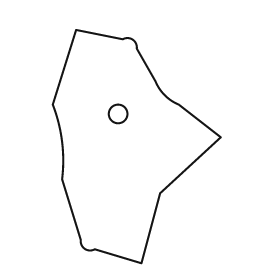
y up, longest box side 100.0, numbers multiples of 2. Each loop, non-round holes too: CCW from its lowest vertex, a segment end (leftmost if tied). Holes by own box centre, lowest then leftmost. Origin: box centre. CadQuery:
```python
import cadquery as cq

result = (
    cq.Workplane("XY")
    .moveTo(2.0, -50.0)
    .lineTo(10.0, -20.0)
    .lineTo(36.0, 4.0)
    .lineTo(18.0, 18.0)
    .threePointArc((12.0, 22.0), (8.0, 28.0))
    .lineTo(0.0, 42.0)
    .threePointArc((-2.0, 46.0), (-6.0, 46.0))
    .lineTo(-26.0, 50.0)
    .lineTo(-36.0, 18.0)
    .threePointArc((-32.0, 2.0), (-32.0, -14.0))
    .lineTo(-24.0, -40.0)
    .threePointArc((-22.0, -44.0), (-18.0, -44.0))
    .close()
    .moveTo(-8.0, 14.0)
    .circle(4.0)
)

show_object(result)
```